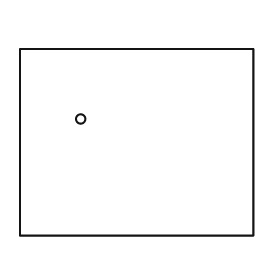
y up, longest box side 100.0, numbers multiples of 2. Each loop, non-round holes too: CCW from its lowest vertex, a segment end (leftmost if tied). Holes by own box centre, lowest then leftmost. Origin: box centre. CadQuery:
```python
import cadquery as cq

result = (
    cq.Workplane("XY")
    .moveTo(-50.0, -40.0)
    .lineTo(50.0, -40.0)
    .lineTo(50.0, 40.0)
    .lineTo(-50.0, 40.0)
    .close()
    .moveTo(-24.0, 10.0)
    .circle(2.0)
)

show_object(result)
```